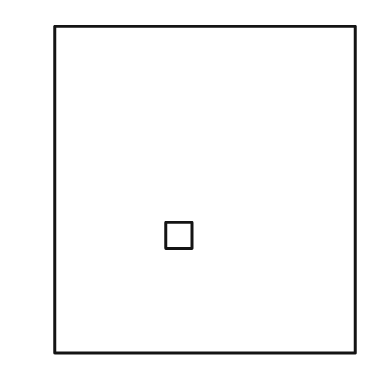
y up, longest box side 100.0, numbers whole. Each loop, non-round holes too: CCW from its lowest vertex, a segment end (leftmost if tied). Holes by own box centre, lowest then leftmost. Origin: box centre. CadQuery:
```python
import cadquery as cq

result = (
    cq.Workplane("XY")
    .moveTo(-46.0, -50.0)
    .lineTo(46.0, -50.0)
    .lineTo(46.0, 50.0)
    .lineTo(-46.0, 50.0)
    .close()
    .moveTo(-12.0, -18.0)
    .lineTo(-4.0, -18.0)
    .lineTo(-4.0, -10.0)
    .lineTo(-12.0, -10.0)
    .close()
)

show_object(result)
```